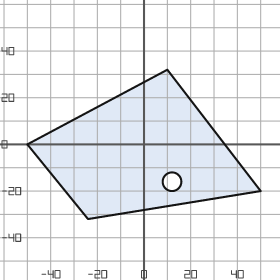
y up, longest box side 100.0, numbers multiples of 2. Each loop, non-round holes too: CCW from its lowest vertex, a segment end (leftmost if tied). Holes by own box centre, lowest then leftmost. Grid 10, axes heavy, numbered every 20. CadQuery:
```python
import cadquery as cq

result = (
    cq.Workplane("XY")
    .moveTo(-24.0, -32.0)
    .lineTo(50.0, -20.0)
    .lineTo(10.0, 32.0)
    .lineTo(-50.0, 0.0)
    .close()
    .moveTo(12.0, -16.0)
    .circle(4.0)
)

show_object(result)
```